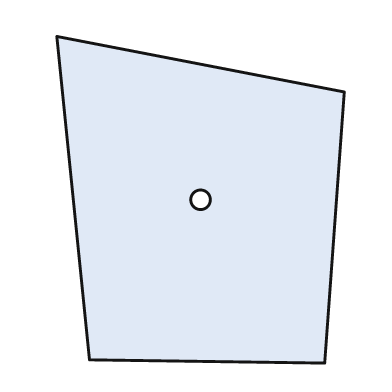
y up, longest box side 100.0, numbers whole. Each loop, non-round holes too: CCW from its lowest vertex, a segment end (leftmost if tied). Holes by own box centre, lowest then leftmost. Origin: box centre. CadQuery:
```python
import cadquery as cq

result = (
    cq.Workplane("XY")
    .moveTo(38.0, -50.0)
    .lineTo(44.0, 33.0)
    .lineTo(-44.0, 50.0)
    .lineTo(-34.0, -49.0)
    .close()
    .moveTo(0.0, 0.0)
    .circle(3.0)
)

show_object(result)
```